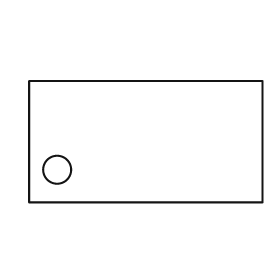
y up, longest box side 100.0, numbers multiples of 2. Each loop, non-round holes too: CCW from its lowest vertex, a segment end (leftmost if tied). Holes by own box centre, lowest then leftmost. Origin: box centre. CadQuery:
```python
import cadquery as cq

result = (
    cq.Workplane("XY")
    .moveTo(-50.0, -26.0)
    .lineTo(50.0, -26.0)
    .lineTo(50.0, 26.0)
    .lineTo(-50.0, 26.0)
    .close()
    .moveTo(-38.0, -12.0)
    .circle(6.0)
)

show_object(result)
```